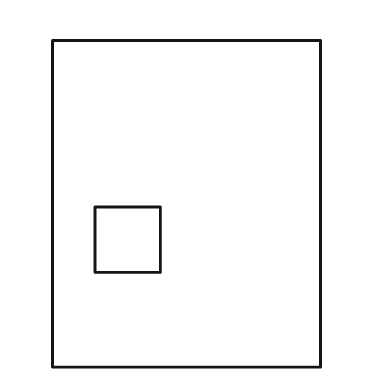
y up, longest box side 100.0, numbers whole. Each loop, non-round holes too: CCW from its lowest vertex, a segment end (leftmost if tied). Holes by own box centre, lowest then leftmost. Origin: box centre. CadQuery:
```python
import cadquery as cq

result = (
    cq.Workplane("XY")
    .moveTo(-41.0, -50.0)
    .lineTo(41.0, -50.0)
    .lineTo(41.0, 50.0)
    .lineTo(-41.0, 50.0)
    .close()
    .moveTo(-28.0, -21.0)
    .lineTo(-8.0, -21.0)
    .lineTo(-8.0, -1.0)
    .lineTo(-28.0, -1.0)
    .close()
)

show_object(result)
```